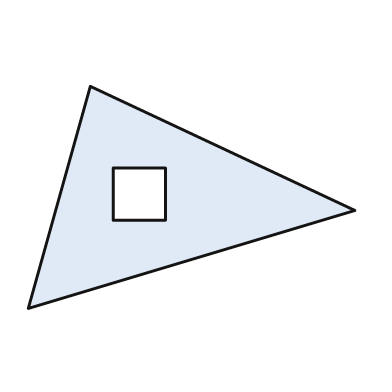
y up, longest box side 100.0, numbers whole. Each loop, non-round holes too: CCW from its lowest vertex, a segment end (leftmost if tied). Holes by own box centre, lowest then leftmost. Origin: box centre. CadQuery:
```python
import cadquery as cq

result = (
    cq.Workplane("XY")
    .moveTo(-50.0, -34.0)
    .lineTo(50.0, -4.0)
    .lineTo(-31.0, 34.0)
    .close()
    .moveTo(-24.0, -7.0)
    .lineTo(-8.0, -7.0)
    .lineTo(-8.0, 9.0)
    .lineTo(-24.0, 9.0)
    .close()
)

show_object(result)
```